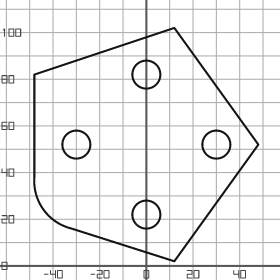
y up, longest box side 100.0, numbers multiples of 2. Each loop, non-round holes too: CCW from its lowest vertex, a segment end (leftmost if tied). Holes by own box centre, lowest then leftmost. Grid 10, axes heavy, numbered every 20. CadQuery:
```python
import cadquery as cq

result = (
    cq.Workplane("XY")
    .moveTo(12.0, 2.0)
    .lineTo(48.0, 52.0)
    .lineTo(12.0, 102.0)
    .lineTo(-48.0, 82.0)
    .lineTo(-48.0, 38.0)
    .threePointArc((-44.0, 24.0), (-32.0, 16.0))
    .close()
    .moveTo(0.0, 22.0)
    .circle(6.0)
    .moveTo(-30.0, 52.0)
    .circle(6.0)
    .moveTo(30.0, 52.0)
    .circle(6.0)
    .moveTo(0.0, 82.0)
    .circle(6.0)
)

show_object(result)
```